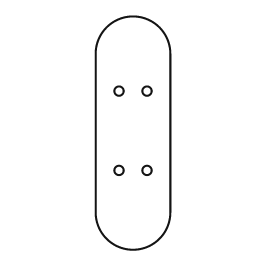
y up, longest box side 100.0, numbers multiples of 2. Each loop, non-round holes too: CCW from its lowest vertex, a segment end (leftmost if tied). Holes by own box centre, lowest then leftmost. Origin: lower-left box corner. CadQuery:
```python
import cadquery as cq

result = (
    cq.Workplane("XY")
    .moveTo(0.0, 16.0)
    .threePointArc((16.0, 0.0), (32.0, 16.0))
    .lineTo(32.0, 84.0)
    .threePointArc((16.0, 100.0), (0.0, 84.0))
    .close()
    .moveTo(10.0, 34.0)
    .circle(2.0)
    .moveTo(22.0, 34.0)
    .circle(2.0)
    .moveTo(10.0, 68.0)
    .circle(2.0)
    .moveTo(22.0, 68.0)
    .circle(2.0)
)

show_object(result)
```